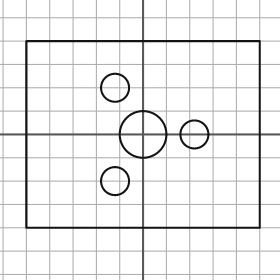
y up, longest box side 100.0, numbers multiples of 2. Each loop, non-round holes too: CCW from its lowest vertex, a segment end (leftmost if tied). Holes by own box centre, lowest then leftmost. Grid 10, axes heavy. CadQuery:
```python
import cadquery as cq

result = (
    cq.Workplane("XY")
    .moveTo(-50.0, -40.0)
    .lineTo(50.0, -40.0)
    .lineTo(50.0, 40.0)
    .lineTo(-50.0, 40.0)
    .close()
    .moveTo(-12.0, -20.0)
    .circle(6.0)
    .moveTo(0.0, 0.0)
    .circle(10.0)
    .moveTo(22.0, 0.0)
    .circle(6.0)
    .moveTo(-12.0, 20.0)
    .circle(6.0)
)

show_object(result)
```